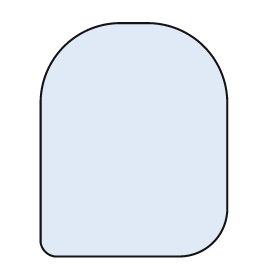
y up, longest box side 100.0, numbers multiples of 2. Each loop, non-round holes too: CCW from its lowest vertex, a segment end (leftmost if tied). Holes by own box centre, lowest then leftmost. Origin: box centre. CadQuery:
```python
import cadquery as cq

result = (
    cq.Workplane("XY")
    .moveTo(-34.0, -50.0)
    .lineTo(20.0, -50.0)
    .threePointArc((34.0, -44.0), (40.0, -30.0))
    .lineTo(40.0, 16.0)
    .threePointArc((30.0, 40.0), (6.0, 50.0))
    .lineTo(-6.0, 50.0)
    .threePointArc((-30.0, 40.0), (-40.0, 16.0))
    .lineTo(-40.0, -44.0)
    .threePointArc((-38.0, -48.0), (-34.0, -50.0))
    .close()
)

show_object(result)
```